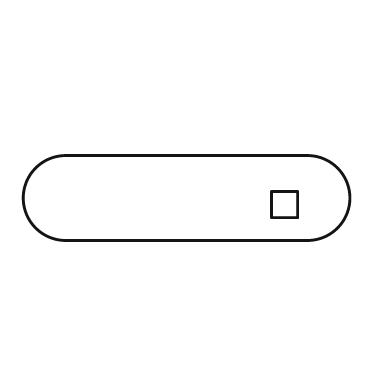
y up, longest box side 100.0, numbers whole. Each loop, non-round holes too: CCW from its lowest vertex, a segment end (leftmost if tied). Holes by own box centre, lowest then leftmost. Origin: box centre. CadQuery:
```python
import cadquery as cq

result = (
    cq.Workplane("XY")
    .moveTo(-37.0, -13.0)
    .lineTo(37.0, -13.0)
    .threePointArc((50.0, 0.0), (37.0, 13.0))
    .lineTo(-37.0, 13.0)
    .threePointArc((-50.0, 0.0), (-37.0, -13.0))
    .close()
    .moveTo(26.0, -6.0)
    .lineTo(34.0, -6.0)
    .lineTo(34.0, 2.0)
    .lineTo(26.0, 2.0)
    .close()
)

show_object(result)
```